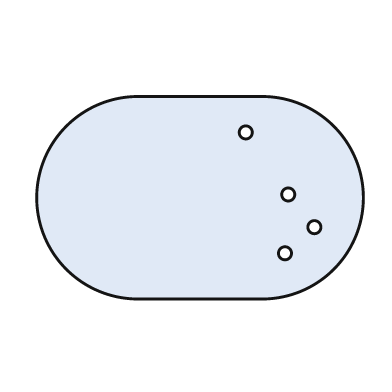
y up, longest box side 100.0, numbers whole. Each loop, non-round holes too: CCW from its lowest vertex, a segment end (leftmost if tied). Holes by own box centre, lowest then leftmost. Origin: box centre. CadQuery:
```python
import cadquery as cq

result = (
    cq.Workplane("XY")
    .moveTo(-19.0, -31.0)
    .lineTo(19.0, -31.0)
    .threePointArc((50.0, 0.0), (19.0, 31.0))
    .lineTo(-19.0, 31.0)
    .threePointArc((-50.0, 0.0), (-19.0, -31.0))
    .close()
    .moveTo(26.0, -17.0)
    .circle(2.0)
    .moveTo(35.0, -9.0)
    .circle(2.0)
    .moveTo(27.0, 1.0)
    .circle(2.0)
    .moveTo(14.0, 20.0)
    .circle(2.0)
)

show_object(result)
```